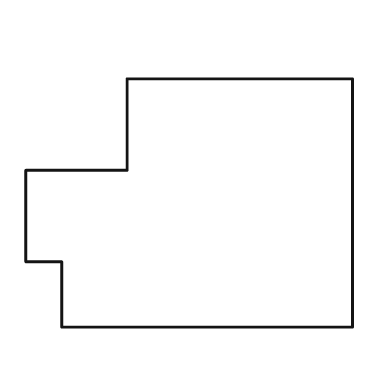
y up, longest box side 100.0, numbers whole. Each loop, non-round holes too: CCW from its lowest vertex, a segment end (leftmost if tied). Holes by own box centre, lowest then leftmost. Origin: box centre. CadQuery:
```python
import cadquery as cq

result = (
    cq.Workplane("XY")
    .moveTo(-39.0, -38.0)
    .lineTo(50.0, -38.0)
    .lineTo(50.0, 38.0)
    .lineTo(-19.0, 38.0)
    .lineTo(-19.0, 10.0)
    .lineTo(-50.0, 10.0)
    .lineTo(-50.0, -18.0)
    .lineTo(-39.0, -18.0)
    .close()
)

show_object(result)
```